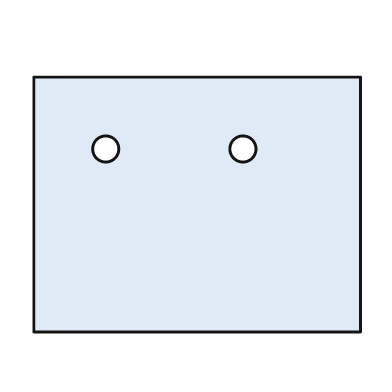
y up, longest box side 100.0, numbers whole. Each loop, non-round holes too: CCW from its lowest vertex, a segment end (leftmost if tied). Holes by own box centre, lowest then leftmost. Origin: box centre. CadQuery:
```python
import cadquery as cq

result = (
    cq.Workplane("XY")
    .moveTo(-50.0, -39.0)
    .lineTo(50.0, -39.0)
    .lineTo(50.0, 39.0)
    .lineTo(-50.0, 39.0)
    .close()
    .moveTo(-28.0, 17.0)
    .circle(4.0)
    .moveTo(14.0, 17.0)
    .circle(4.0)
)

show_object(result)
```